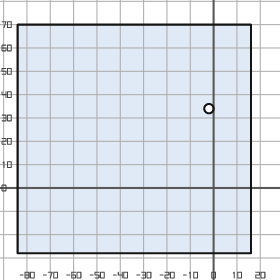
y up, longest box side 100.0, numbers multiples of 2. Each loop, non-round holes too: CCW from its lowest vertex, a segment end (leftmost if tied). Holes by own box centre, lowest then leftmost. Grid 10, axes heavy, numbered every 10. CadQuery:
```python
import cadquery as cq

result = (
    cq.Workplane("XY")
    .moveTo(-84.0, -28.0)
    .lineTo(16.0, -28.0)
    .lineTo(16.0, 70.0)
    .lineTo(-84.0, 70.0)
    .close()
    .moveTo(-2.0, 34.0)
    .circle(2.0)
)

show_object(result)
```